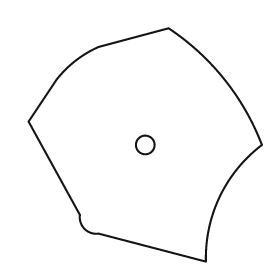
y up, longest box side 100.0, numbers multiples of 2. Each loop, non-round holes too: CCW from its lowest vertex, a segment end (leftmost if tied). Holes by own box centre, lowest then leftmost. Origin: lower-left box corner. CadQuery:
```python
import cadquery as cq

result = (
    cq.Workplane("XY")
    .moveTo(76.0, 0.0)
    .threePointArc((82.0, 28.0), (100.0, 50.0))
    .threePointArc((84.0, 78.0), (60.0, 100.0))
    .lineTo(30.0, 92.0)
    .threePointArc((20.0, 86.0), (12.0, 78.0))
    .lineTo(0.0, 60.0)
    .lineTo(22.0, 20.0)
    .threePointArc((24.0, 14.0), (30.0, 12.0))
    .close()
    .moveTo(50.0, 50.0)
    .circle(4.0)
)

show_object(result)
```